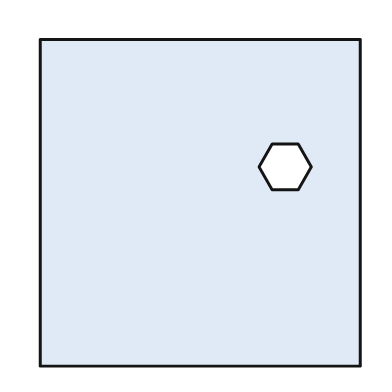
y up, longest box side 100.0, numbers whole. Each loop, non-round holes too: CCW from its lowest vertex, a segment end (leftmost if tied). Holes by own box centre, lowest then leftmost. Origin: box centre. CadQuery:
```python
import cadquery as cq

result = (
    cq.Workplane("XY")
    .moveTo(-49.0, -50.0)
    .lineTo(49.0, -50.0)
    .lineTo(49.0, 50.0)
    .lineTo(-49.0, 50.0)
    .close()
    .moveTo(22.0, 4.0)
    .lineTo(30.0, 4.0)
    .lineTo(34.0, 11.0)
    .lineTo(30.0, 18.0)
    .lineTo(22.0, 18.0)
    .lineTo(18.0, 11.0)
    .close()
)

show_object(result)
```